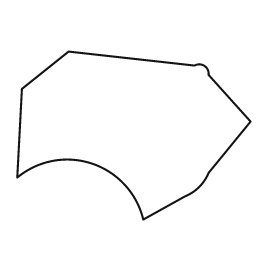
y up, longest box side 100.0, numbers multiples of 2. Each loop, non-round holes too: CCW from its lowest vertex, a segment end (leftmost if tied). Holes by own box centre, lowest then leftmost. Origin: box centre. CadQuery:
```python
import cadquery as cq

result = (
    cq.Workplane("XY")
    .moveTo(4.0, -36.0)
    .lineTo(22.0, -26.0)
    .threePointArc((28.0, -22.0), (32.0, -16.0))
    .lineTo(50.0, 6.0)
    .lineTo(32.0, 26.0)
    .threePointArc((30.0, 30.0), (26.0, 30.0))
    .lineTo(-28.0, 36.0)
    .lineTo(-48.0, 20.0)
    .lineTo(-50.0, -18.0)
    .threePointArc((-18.0, -12.0), (4.0, -36.0))
    .close()
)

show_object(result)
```